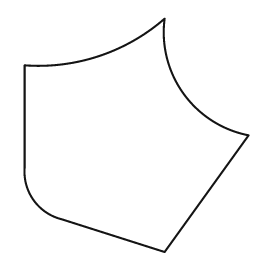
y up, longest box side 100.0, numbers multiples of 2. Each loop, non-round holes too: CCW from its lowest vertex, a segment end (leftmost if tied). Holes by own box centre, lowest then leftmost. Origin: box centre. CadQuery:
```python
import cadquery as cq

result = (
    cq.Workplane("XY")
    .moveTo(12.0, -50.0)
    .lineTo(48.0, 0.0)
    .threePointArc((20.0, 18.0), (12.0, 50.0))
    .threePointArc((-16.0, 34.0), (-48.0, 30.0))
    .lineTo(-48.0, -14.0)
    .threePointArc((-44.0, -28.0), (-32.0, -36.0))
    .close()
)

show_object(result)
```